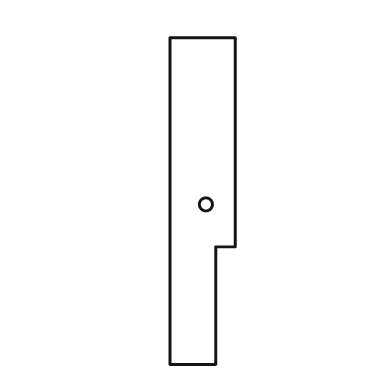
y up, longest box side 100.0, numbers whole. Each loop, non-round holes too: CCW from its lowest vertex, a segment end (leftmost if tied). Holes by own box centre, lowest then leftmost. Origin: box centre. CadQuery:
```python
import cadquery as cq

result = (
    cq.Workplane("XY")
    .moveTo(-10.0, -50.0)
    .lineTo(4.0, -50.0)
    .lineTo(4.0, -14.0)
    .lineTo(10.0, -14.0)
    .lineTo(10.0, 50.0)
    .lineTo(-10.0, 50.0)
    .close()
    .moveTo(1.0, -1.0)
    .circle(2.0)
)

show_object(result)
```